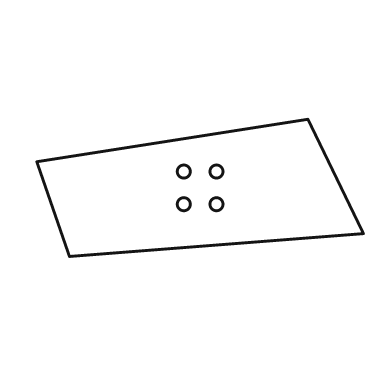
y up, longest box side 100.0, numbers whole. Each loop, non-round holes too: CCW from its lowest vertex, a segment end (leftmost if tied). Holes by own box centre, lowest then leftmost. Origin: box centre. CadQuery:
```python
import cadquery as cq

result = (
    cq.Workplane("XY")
    .moveTo(-40.0, -21.0)
    .lineTo(50.0, -14.0)
    .lineTo(33.0, 21.0)
    .lineTo(-50.0, 8.0)
    .close()
    .moveTo(-5.0, -5.0)
    .circle(2.0)
    .moveTo(5.0, -5.0)
    .circle(2.0)
    .moveTo(-5.0, 5.0)
    .circle(2.0)
    .moveTo(5.0, 5.0)
    .circle(2.0)
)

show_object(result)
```